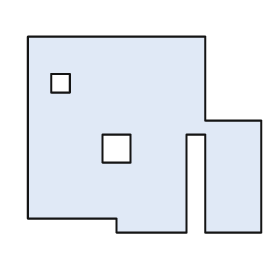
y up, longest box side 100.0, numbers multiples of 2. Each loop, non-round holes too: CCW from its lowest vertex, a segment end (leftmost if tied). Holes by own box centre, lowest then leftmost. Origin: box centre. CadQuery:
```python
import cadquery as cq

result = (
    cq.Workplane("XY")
    .moveTo(-12.0, -42.0)
    .lineTo(18.0, -42.0)
    .lineTo(18.0, 0.0)
    .lineTo(26.0, 0.0)
    .lineTo(26.0, -42.0)
    .lineTo(50.0, -42.0)
    .lineTo(50.0, 6.0)
    .lineTo(26.0, 6.0)
    .lineTo(26.0, 42.0)
    .lineTo(-50.0, 42.0)
    .lineTo(-50.0, -36.0)
    .lineTo(-12.0, -36.0)
    .close()
    .moveTo(-18.0, -12.0)
    .lineTo(-6.0, -12.0)
    .lineTo(-6.0, 0.0)
    .lineTo(-18.0, 0.0)
    .close()
    .moveTo(-40.0, 18.0)
    .lineTo(-32.0, 18.0)
    .lineTo(-32.0, 26.0)
    .lineTo(-40.0, 26.0)
    .close()
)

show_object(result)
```